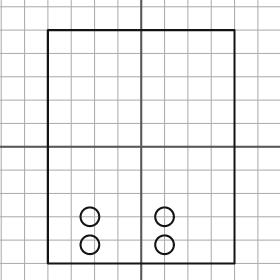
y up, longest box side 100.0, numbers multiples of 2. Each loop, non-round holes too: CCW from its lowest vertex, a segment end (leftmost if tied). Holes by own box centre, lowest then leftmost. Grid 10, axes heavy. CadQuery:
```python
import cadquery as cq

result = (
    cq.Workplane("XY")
    .moveTo(-40.0, -50.0)
    .lineTo(40.0, -50.0)
    .lineTo(40.0, 50.0)
    .lineTo(-40.0, 50.0)
    .close()
    .moveTo(-22.0, -42.0)
    .circle(4.0)
    .moveTo(10.0, -42.0)
    .circle(4.0)
    .moveTo(-22.0, -30.0)
    .circle(4.0)
    .moveTo(10.0, -30.0)
    .circle(4.0)
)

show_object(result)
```